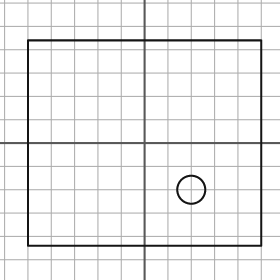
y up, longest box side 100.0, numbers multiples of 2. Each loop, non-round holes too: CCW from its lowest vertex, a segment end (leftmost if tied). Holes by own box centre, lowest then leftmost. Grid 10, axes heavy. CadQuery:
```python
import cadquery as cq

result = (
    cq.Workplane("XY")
    .moveTo(-50.0, -44.0)
    .lineTo(50.0, -44.0)
    .lineTo(50.0, 44.0)
    .lineTo(-50.0, 44.0)
    .close()
    .moveTo(20.0, -20.0)
    .circle(6.0)
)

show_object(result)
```